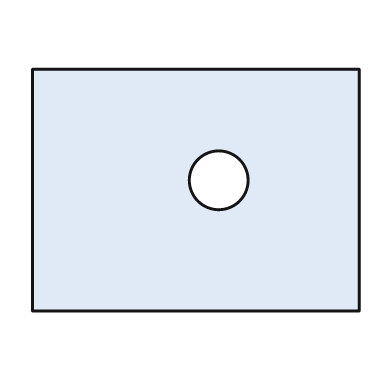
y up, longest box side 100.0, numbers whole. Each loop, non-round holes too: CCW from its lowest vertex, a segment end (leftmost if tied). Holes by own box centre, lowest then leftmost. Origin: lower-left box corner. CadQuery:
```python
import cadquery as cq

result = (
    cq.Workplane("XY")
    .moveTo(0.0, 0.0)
    .lineTo(100.0, 0.0)
    .lineTo(100.0, 74.0)
    .lineTo(0.0, 74.0)
    .close()
    .moveTo(57.0, 40.0)
    .circle(9.0)
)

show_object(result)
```